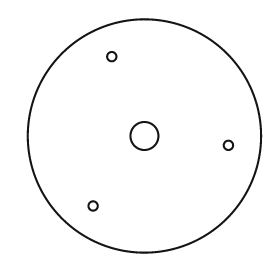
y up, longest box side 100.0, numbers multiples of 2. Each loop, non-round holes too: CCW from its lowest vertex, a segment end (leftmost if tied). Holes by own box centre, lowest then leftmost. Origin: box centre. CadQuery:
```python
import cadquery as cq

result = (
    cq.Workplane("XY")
    .moveTo(0.0, 0.0)
    .circle(50.0)
    .moveTo(-22.0, -30.0)
    .circle(2.0)
    .moveTo(36.0, -4.0)
    .circle(2.0)
    .moveTo(0.0, 0.0)
    .circle(6.0)
    .moveTo(-14.0, 34.0)
    .circle(2.0)
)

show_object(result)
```